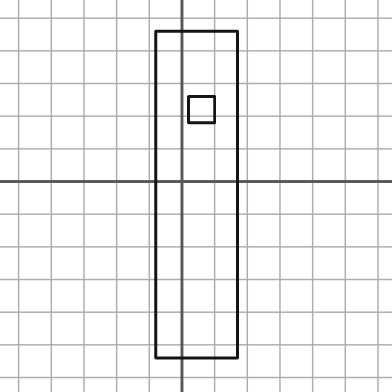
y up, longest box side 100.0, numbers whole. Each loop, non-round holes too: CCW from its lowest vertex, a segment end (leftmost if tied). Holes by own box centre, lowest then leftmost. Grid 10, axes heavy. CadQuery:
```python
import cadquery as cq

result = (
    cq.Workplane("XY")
    .moveTo(-8.0, -54.0)
    .lineTo(17.0, -54.0)
    .lineTo(17.0, 46.0)
    .lineTo(-8.0, 46.0)
    .close()
    .moveTo(2.0, 18.0)
    .lineTo(10.0, 18.0)
    .lineTo(10.0, 26.0)
    .lineTo(2.0, 26.0)
    .close()
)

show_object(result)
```